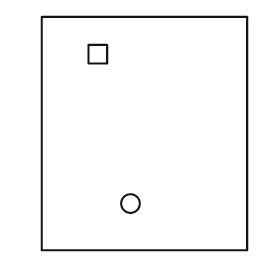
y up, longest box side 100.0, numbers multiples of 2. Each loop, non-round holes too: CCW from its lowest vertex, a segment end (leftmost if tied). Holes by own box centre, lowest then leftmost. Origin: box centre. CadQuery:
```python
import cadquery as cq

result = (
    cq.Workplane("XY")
    .moveTo(-44.0, -50.0)
    .lineTo(44.0, -50.0)
    .lineTo(44.0, 50.0)
    .lineTo(-44.0, 50.0)
    .close()
    .moveTo(-6.0, -30.0)
    .circle(4.0)
    .moveTo(-24.0, 30.0)
    .lineTo(-16.0, 30.0)
    .lineTo(-16.0, 38.0)
    .lineTo(-24.0, 38.0)
    .close()
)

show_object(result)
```